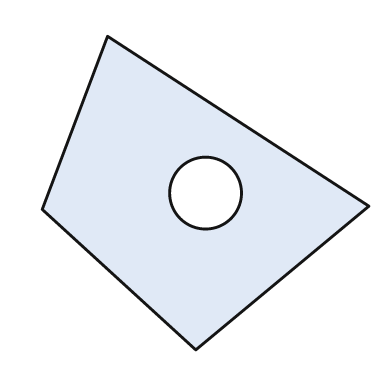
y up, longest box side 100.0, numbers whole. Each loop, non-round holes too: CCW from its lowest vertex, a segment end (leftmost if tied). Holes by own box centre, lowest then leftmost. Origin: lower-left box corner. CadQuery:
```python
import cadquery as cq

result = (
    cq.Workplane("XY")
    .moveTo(47.0, 0.0)
    .lineTo(100.0, 44.0)
    .lineTo(20.0, 96.0)
    .lineTo(0.0, 43.0)
    .close()
    .moveTo(50.0, 48.0)
    .circle(11.0)
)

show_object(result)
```